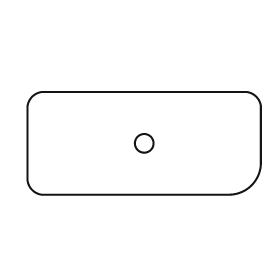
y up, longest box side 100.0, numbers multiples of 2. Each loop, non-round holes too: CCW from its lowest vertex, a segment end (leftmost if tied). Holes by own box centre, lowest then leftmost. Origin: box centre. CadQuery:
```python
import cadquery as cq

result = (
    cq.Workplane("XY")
    .moveTo(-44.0, -22.0)
    .lineTo(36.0, -22.0)
    .threePointArc((46.0, -18.0), (50.0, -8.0))
    .lineTo(50.0, 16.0)
    .threePointArc((48.0, 20.0), (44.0, 22.0))
    .lineTo(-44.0, 22.0)
    .threePointArc((-48.0, 20.0), (-50.0, 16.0))
    .lineTo(-50.0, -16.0)
    .threePointArc((-48.0, -20.0), (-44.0, -22.0))
    .close()
    .moveTo(0.0, 0.0)
    .circle(4.0)
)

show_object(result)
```